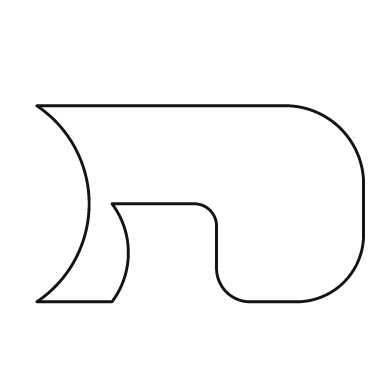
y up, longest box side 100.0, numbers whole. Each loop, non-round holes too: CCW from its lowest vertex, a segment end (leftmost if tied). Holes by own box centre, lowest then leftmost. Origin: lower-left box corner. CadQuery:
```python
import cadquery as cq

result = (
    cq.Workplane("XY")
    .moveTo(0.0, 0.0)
    .lineTo(23.0, 0.0)
    .threePointArc((28.0, 15.0), (23.0, 30.0))
    .lineTo(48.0, 30.0)
    .threePointArc((53.0, 28.0), (55.0, 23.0))
    .lineTo(55.0, 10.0)
    .threePointArc((58.0, 3.0), (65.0, 0.0))
    .lineTo(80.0, 0.0)
    .threePointArc((94.0, 6.0), (100.0, 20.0))
    .lineTo(100.0, 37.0)
    .threePointArc((93.0, 53.0), (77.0, 60.0))
    .lineTo(0.0, 60.0)
    .threePointArc((16.0, 30.0), (0.0, 0.0))
    .close()
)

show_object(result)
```